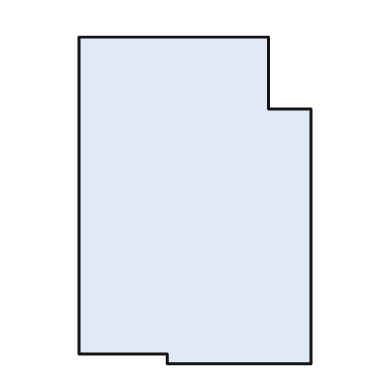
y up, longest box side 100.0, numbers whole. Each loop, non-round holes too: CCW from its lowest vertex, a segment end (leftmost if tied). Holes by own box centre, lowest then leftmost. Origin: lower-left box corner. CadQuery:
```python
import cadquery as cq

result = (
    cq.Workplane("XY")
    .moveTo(27.0, 0.0)
    .lineTo(71.0, 0.0)
    .lineTo(71.0, 78.0)
    .lineTo(58.0, 78.0)
    .lineTo(58.0, 100.0)
    .lineTo(0.0, 100.0)
    .lineTo(0.0, 3.0)
    .lineTo(27.0, 3.0)
    .close()
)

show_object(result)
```